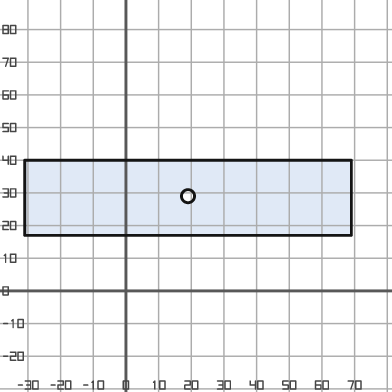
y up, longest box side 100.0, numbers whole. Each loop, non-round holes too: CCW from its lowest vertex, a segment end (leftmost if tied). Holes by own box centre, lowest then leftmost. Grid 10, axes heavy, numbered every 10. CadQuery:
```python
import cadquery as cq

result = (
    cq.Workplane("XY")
    .moveTo(-31.0, 17.0)
    .lineTo(69.0, 17.0)
    .lineTo(69.0, 40.0)
    .lineTo(-31.0, 40.0)
    .close()
    .moveTo(19.0, 29.0)
    .circle(2.0)
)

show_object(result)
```